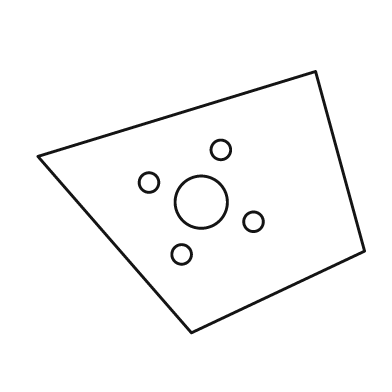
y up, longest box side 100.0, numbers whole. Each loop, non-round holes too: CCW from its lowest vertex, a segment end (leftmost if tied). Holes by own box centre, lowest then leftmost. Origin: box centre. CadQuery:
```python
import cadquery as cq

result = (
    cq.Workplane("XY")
    .moveTo(-3.0, -40.0)
    .lineTo(50.0, -15.0)
    .lineTo(35.0, 40.0)
    .lineTo(-50.0, 14.0)
    .close()
    .moveTo(-6.0, -16.0)
    .circle(3.0)
    .moveTo(16.0, -6.0)
    .circle(3.0)
    .moveTo(0.0, 0.0)
    .circle(8.0)
    .moveTo(-16.0, 6.0)
    .circle(3.0)
    .moveTo(6.0, 16.0)
    .circle(3.0)
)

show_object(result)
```